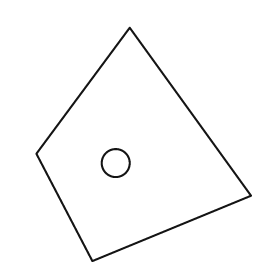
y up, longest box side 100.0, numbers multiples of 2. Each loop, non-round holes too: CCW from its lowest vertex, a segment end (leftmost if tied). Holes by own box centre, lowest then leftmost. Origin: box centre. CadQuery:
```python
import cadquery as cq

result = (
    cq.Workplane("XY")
    .moveTo(-22.0, -50.0)
    .lineTo(46.0, -22.0)
    .lineTo(-6.0, 50.0)
    .lineTo(-46.0, -4.0)
    .close()
    .moveTo(-12.0, -8.0)
    .circle(6.0)
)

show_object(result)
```